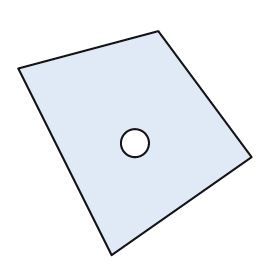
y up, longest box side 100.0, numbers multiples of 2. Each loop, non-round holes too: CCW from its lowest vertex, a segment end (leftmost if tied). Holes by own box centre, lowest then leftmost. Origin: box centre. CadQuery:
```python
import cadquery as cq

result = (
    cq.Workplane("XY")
    .moveTo(-10.0, -48.0)
    .lineTo(50.0, -6.0)
    .lineTo(10.0, 48.0)
    .lineTo(-50.0, 32.0)
    .close()
    .moveTo(0.0, 0.0)
    .circle(6.0)
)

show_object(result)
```